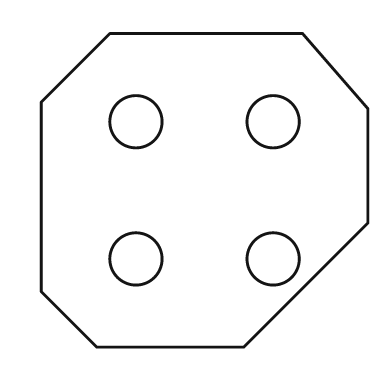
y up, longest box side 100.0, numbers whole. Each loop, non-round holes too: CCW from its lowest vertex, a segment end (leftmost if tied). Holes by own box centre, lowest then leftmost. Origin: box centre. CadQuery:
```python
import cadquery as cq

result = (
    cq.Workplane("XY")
    .moveTo(-33.0, -48.0)
    .lineTo(12.0, -48.0)
    .lineTo(50.0, -10.0)
    .lineTo(50.0, 25.0)
    .lineTo(30.0, 48.0)
    .lineTo(-29.0, 48.0)
    .lineTo(-50.0, 27.0)
    .lineTo(-50.0, -31.0)
    .close()
    .moveTo(-21.0, -21.0)
    .circle(8.0)
    .moveTo(21.0, -21.0)
    .circle(8.0)
    .moveTo(-21.0, 21.0)
    .circle(8.0)
    .moveTo(21.0, 21.0)
    .circle(8.0)
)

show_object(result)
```